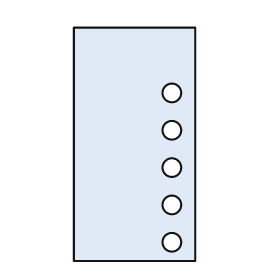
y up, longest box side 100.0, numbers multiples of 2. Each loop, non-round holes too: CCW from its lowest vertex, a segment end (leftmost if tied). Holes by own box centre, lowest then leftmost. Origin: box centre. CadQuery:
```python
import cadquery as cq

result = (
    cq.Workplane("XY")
    .moveTo(-26.0, -50.0)
    .lineTo(26.0, -50.0)
    .lineTo(26.0, 50.0)
    .lineTo(-26.0, 50.0)
    .close()
    .moveTo(16.0, -42.0)
    .circle(4.0)
    .moveTo(16.0, -26.0)
    .circle(4.0)
    .moveTo(16.0, -10.0)
    .circle(4.0)
    .moveTo(16.0, 6.0)
    .circle(4.0)
    .moveTo(16.0, 22.0)
    .circle(4.0)
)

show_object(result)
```